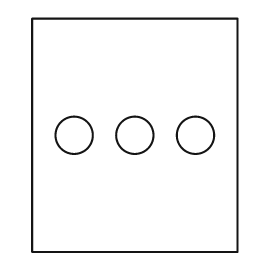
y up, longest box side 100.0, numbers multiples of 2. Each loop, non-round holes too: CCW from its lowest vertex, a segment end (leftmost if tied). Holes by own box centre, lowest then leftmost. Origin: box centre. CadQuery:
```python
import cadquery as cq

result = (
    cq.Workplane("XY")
    .moveTo(-44.0, -50.0)
    .lineTo(44.0, -50.0)
    .lineTo(44.0, 50.0)
    .lineTo(-44.0, 50.0)
    .close()
    .moveTo(-26.0, 0.0)
    .circle(8.0)
    .moveTo(0.0, 0.0)
    .circle(8.0)
    .moveTo(26.0, 0.0)
    .circle(8.0)
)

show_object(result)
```